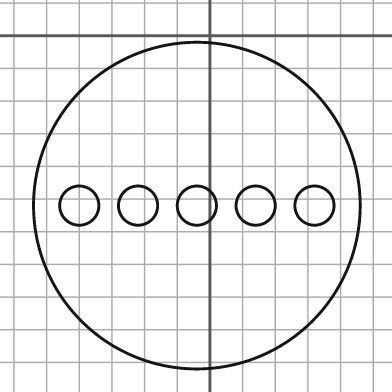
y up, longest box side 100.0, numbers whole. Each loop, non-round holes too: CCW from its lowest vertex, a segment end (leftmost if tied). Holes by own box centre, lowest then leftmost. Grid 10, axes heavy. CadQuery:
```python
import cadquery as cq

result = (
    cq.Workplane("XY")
    .moveTo(-4.0, -52.0)
    .circle(50.0)
    .moveTo(-40.0, -52.0)
    .circle(6.0)
    .moveTo(-22.0, -52.0)
    .circle(6.0)
    .moveTo(-4.0, -52.0)
    .circle(6.0)
    .moveTo(14.0, -52.0)
    .circle(6.0)
    .moveTo(32.0, -52.0)
    .circle(6.0)
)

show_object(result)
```